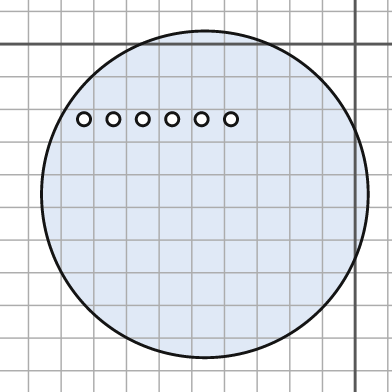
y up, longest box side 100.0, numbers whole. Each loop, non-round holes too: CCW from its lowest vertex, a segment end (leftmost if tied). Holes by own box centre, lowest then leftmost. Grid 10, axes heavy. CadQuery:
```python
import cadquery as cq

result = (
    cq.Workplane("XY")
    .moveTo(-46.0, -46.0)
    .circle(50.0)
    .moveTo(-83.0, -23.0)
    .circle(2.0)
    .moveTo(-74.0, -23.0)
    .circle(2.0)
    .moveTo(-65.0, -23.0)
    .circle(2.0)
    .moveTo(-56.0, -23.0)
    .circle(2.0)
    .moveTo(-47.0, -23.0)
    .circle(2.0)
    .moveTo(-38.0, -23.0)
    .circle(2.0)
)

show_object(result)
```